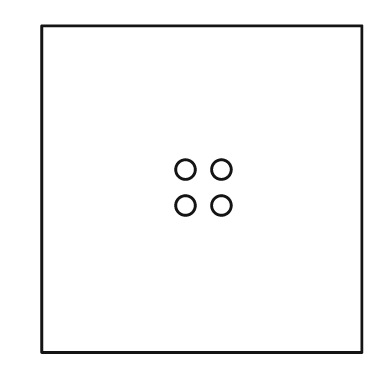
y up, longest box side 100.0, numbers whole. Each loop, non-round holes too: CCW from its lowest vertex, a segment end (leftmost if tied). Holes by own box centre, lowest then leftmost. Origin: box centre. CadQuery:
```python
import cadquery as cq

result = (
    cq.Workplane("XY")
    .moveTo(-49.0, -50.0)
    .lineTo(49.0, -50.0)
    .lineTo(49.0, 50.0)
    .lineTo(-49.0, 50.0)
    .close()
    .moveTo(-5.0, -5.0)
    .circle(3.0)
    .moveTo(6.0, -5.0)
    .circle(3.0)
    .moveTo(-5.0, 6.0)
    .circle(3.0)
    .moveTo(6.0, 6.0)
    .circle(3.0)
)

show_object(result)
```